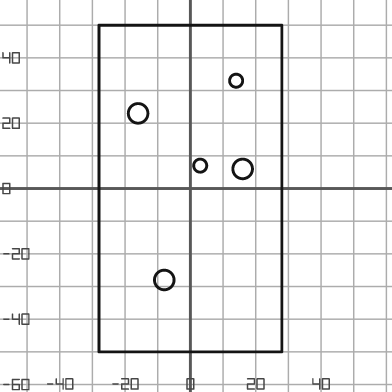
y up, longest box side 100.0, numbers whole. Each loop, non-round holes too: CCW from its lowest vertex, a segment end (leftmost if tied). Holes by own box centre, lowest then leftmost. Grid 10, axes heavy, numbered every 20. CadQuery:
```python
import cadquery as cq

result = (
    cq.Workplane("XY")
    .moveTo(-28.0, -50.0)
    .lineTo(28.0, -50.0)
    .lineTo(28.0, 50.0)
    .lineTo(-28.0, 50.0)
    .close()
    .moveTo(-8.0, -28.0)
    .circle(3.0)
    .moveTo(16.0, 6.0)
    .circle(3.0)
    .moveTo(3.0, 7.0)
    .circle(2.0)
    .moveTo(-16.0, 23.0)
    .circle(3.0)
    .moveTo(14.0, 33.0)
    .circle(2.0)
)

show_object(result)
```